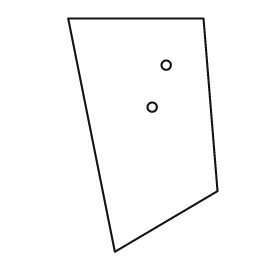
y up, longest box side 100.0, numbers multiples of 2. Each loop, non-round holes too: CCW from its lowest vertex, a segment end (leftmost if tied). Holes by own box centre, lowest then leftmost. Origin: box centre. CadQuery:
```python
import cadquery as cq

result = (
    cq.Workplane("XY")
    .moveTo(-12.0, -50.0)
    .lineTo(32.0, -24.0)
    .lineTo(26.0, 50.0)
    .lineTo(-32.0, 50.0)
    .close()
    .moveTo(4.0, 12.0)
    .circle(2.0)
    .moveTo(10.0, 30.0)
    .circle(2.0)
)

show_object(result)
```